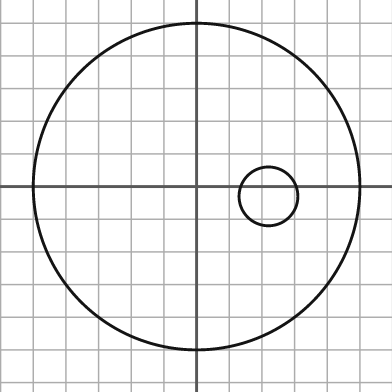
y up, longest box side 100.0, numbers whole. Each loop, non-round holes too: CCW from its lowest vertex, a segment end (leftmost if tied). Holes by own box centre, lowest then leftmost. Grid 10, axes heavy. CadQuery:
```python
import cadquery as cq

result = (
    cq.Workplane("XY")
    .moveTo(0.0, 0.0)
    .circle(50.0)
    .moveTo(22.0, -3.0)
    .circle(9.0)
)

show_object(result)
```